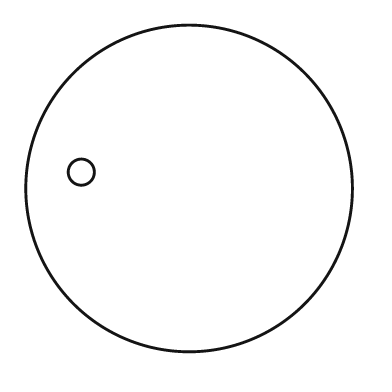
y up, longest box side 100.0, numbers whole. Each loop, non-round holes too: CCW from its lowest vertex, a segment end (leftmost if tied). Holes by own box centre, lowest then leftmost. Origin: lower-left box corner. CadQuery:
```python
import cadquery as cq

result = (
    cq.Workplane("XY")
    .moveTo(50.0, 50.0)
    .circle(50.0)
    .moveTo(17.0, 55.0)
    .circle(4.0)
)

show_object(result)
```